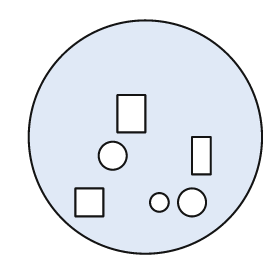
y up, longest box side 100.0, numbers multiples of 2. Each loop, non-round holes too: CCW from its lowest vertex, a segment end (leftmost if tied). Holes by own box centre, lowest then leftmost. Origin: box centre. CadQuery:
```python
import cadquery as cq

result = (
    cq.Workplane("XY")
    .moveTo(0.0, 0.0)
    .circle(50.0)
    .moveTo(-30.0, -34.0)
    .lineTo(-18.0, -34.0)
    .lineTo(-18.0, -22.0)
    .lineTo(-30.0, -22.0)
    .close()
    .moveTo(6.0, -28.0)
    .circle(4.0)
    .moveTo(20.0, -28.0)
    .circle(6.0)
    .moveTo(-14.0, -8.0)
    .circle(6.0)
    .moveTo(20.0, -16.0)
    .lineTo(28.0, -16.0)
    .lineTo(28.0, 0.0)
    .lineTo(20.0, 0.0)
    .close()
    .moveTo(-12.0, 2.0)
    .lineTo(0.0, 2.0)
    .lineTo(0.0, 18.0)
    .lineTo(-12.0, 18.0)
    .close()
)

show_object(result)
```